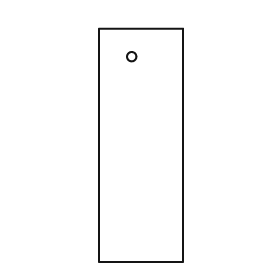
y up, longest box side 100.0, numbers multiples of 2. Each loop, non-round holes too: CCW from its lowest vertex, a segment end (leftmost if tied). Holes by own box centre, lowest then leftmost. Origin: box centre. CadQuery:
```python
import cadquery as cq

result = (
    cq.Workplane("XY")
    .moveTo(-18.0, -50.0)
    .lineTo(18.0, -50.0)
    .lineTo(18.0, 50.0)
    .lineTo(-18.0, 50.0)
    .close()
    .moveTo(-4.0, 38.0)
    .circle(2.0)
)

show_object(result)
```